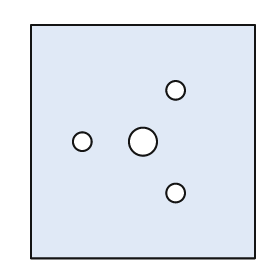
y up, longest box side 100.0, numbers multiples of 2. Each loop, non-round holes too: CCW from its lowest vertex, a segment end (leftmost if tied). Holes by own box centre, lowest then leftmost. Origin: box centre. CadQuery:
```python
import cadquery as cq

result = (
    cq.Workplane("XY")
    .moveTo(-48.0, -50.0)
    .lineTo(48.0, -50.0)
    .lineTo(48.0, 50.0)
    .lineTo(-48.0, 50.0)
    .close()
    .moveTo(14.0, -22.0)
    .circle(4.0)
    .moveTo(-26.0, 0.0)
    .circle(4.0)
    .moveTo(0.0, 0.0)
    .circle(6.0)
    .moveTo(14.0, 22.0)
    .circle(4.0)
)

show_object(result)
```